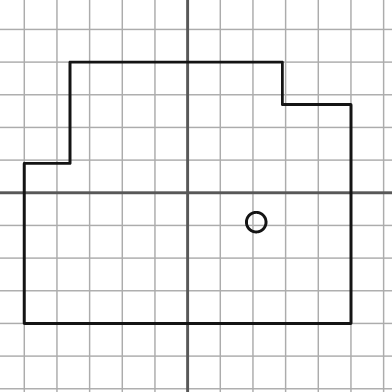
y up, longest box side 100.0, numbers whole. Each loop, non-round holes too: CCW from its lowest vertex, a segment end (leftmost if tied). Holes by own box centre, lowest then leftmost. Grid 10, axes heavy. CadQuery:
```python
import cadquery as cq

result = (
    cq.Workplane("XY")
    .moveTo(-50.0, -40.0)
    .lineTo(50.0, -40.0)
    .lineTo(50.0, 27.0)
    .lineTo(29.0, 27.0)
    .lineTo(29.0, 40.0)
    .lineTo(-36.0, 40.0)
    .lineTo(-36.0, 9.0)
    .lineTo(-50.0, 9.0)
    .close()
    .moveTo(21.0, -9.0)
    .circle(3.0)
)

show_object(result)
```